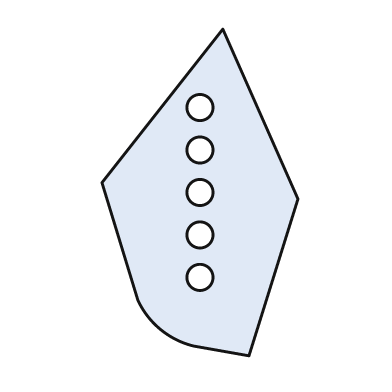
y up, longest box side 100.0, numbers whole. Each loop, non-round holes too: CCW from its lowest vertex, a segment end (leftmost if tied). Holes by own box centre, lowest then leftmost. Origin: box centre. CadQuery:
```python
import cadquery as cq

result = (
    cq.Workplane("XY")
    .moveTo(15.0, -50.0)
    .lineTo(30.0, -2.0)
    .lineTo(7.0, 50.0)
    .lineTo(-30.0, 3.0)
    .lineTo(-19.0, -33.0)
    .threePointArc((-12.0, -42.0), (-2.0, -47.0))
    .close()
    .moveTo(0.0, -26.0)
    .circle(4.0)
    .moveTo(0.0, -13.0)
    .circle(4.0)
    .moveTo(0.0, 0.0)
    .circle(4.0)
    .moveTo(0.0, 13.0)
    .circle(4.0)
    .moveTo(0.0, 26.0)
    .circle(4.0)
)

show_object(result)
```